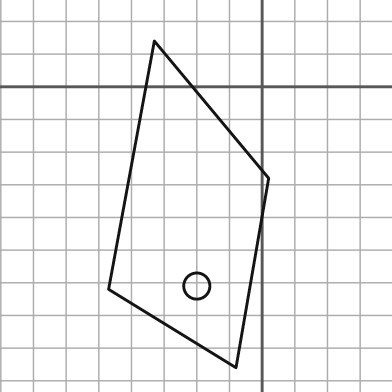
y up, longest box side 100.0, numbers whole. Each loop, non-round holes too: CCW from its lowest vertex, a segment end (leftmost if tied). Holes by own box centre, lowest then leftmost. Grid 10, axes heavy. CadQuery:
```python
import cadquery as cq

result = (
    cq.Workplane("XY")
    .moveTo(-8.0, -86.0)
    .lineTo(2.0, -28.0)
    .lineTo(-33.0, 14.0)
    .lineTo(-47.0, -62.0)
    .close()
    .moveTo(-20.0, -61.0)
    .circle(4.0)
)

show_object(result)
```